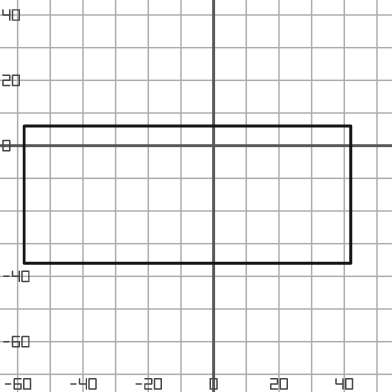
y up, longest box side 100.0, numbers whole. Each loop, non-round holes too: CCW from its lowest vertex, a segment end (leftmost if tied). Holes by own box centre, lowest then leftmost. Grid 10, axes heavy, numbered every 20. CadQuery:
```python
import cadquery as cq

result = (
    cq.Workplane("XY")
    .moveTo(-58.0, -36.0)
    .lineTo(42.0, -36.0)
    .lineTo(42.0, 6.0)
    .lineTo(-58.0, 6.0)
    .close()
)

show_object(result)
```